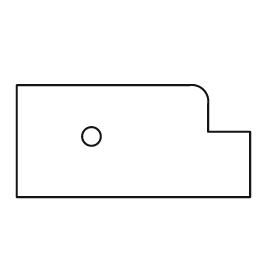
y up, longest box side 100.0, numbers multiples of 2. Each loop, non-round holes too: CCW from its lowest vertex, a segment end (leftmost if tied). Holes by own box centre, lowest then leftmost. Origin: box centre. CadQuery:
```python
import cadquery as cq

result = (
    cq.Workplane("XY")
    .moveTo(-50.0, -24.0)
    .lineTo(50.0, -24.0)
    .lineTo(50.0, 4.0)
    .lineTo(32.0, 4.0)
    .lineTo(32.0, 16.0)
    .threePointArc((30.0, 22.0), (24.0, 24.0))
    .lineTo(-50.0, 24.0)
    .close()
    .moveTo(-18.0, 2.0)
    .circle(4.0)
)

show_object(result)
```